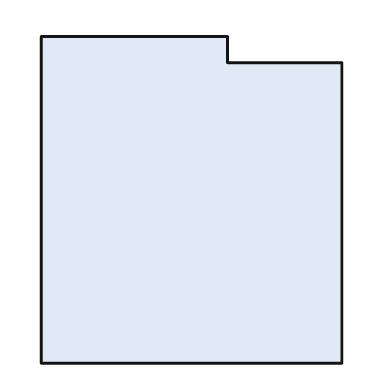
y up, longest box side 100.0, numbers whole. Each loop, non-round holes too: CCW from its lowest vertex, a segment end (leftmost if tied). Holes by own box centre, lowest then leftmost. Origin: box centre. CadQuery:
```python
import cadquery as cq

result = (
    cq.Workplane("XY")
    .moveTo(-46.0, -50.0)
    .lineTo(46.0, -50.0)
    .lineTo(46.0, 42.0)
    .lineTo(11.0, 42.0)
    .lineTo(11.0, 50.0)
    .lineTo(-46.0, 50.0)
    .close()
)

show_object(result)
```